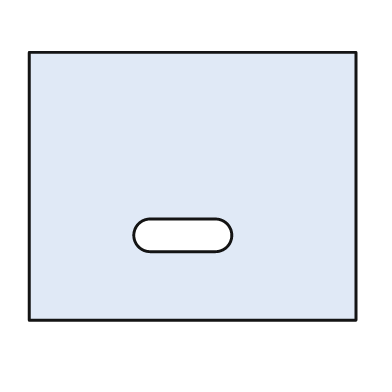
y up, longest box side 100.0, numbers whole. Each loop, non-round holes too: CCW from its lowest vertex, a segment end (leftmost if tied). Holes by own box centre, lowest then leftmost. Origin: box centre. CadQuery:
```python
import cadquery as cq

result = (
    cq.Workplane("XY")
    .moveTo(-50.0, -41.0)
    .lineTo(50.0, -41.0)
    .lineTo(50.0, 41.0)
    .lineTo(-50.0, 41.0)
    .close()
    .moveTo(-13.0, -20.0)
    .lineTo(7.0, -20.0)
    .threePointArc((12.0, -15.0), (7.0, -10.0))
    .lineTo(-13.0, -10.0)
    .threePointArc((-18.0, -15.0), (-13.0, -20.0))
    .close()
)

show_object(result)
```